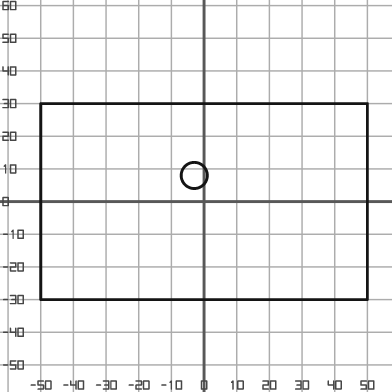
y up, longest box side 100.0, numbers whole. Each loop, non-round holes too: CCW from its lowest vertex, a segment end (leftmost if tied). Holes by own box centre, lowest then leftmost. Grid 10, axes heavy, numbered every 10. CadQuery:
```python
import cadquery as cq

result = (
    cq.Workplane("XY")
    .moveTo(-50.0, -30.0)
    .lineTo(50.0, -30.0)
    .lineTo(50.0, 30.0)
    .lineTo(-50.0, 30.0)
    .close()
    .moveTo(-3.0, 8.0)
    .circle(4.0)
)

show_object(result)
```